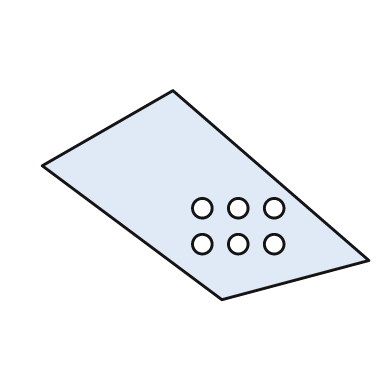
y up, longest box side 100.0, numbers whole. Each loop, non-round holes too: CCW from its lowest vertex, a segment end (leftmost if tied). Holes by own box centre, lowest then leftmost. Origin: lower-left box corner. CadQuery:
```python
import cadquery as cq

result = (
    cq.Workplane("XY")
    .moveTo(55.0, 0.0)
    .lineTo(100.0, 12.0)
    .lineTo(40.0, 64.0)
    .lineTo(0.0, 41.0)
    .close()
    .moveTo(49.0, 17.0)
    .circle(3.0)
    .moveTo(60.0, 17.0)
    .circle(3.0)
    .moveTo(71.0, 17.0)
    .circle(3.0)
    .moveTo(49.0, 28.0)
    .circle(3.0)
    .moveTo(60.0, 28.0)
    .circle(3.0)
    .moveTo(71.0, 28.0)
    .circle(3.0)
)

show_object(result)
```